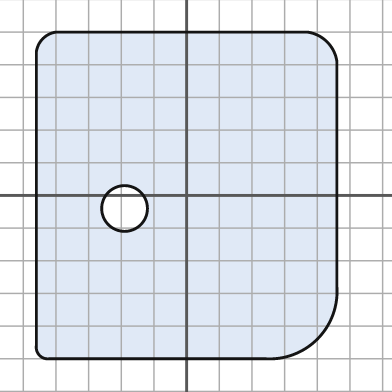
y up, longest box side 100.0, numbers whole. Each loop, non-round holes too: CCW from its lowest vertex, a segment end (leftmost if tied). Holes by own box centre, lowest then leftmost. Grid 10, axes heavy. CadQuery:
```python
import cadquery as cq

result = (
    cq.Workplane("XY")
    .moveTo(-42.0, -50.0)
    .lineTo(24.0, -50.0)
    .threePointArc((40.0, -44.0), (46.0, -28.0))
    .lineTo(46.0, 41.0)
    .threePointArc((43.0, 47.0), (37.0, 50.0))
    .lineTo(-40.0, 50.0)
    .threePointArc((-44.0, 48.0), (-46.0, 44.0))
    .lineTo(-46.0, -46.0)
    .threePointArc((-45.0, -49.0), (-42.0, -50.0))
    .close()
    .moveTo(-19.0, -4.0)
    .circle(7.0)
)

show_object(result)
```